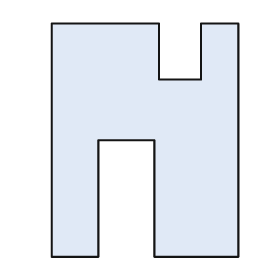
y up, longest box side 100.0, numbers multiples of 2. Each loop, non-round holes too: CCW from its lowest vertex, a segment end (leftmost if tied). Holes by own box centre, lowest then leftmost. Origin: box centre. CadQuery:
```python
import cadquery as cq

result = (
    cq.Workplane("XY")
    .moveTo(-40.0, -50.0)
    .lineTo(-20.0, -50.0)
    .lineTo(-20.0, 0.0)
    .lineTo(4.0, 0.0)
    .lineTo(4.0, -50.0)
    .lineTo(40.0, -50.0)
    .lineTo(40.0, 50.0)
    .lineTo(24.0, 50.0)
    .lineTo(24.0, 26.0)
    .lineTo(6.0, 26.0)
    .lineTo(6.0, 50.0)
    .lineTo(-40.0, 50.0)
    .close()
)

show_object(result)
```